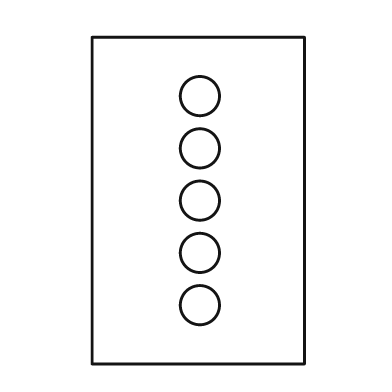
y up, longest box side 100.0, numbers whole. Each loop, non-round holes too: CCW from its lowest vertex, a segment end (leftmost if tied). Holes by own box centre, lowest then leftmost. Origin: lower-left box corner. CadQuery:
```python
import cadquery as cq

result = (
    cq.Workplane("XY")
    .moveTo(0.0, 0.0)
    .lineTo(65.0, 0.0)
    .lineTo(65.0, 100.0)
    .lineTo(0.0, 100.0)
    .close()
    .moveTo(33.0, 18.0)
    .circle(6.0)
    .moveTo(33.0, 34.0)
    .circle(6.0)
    .moveTo(33.0, 50.0)
    .circle(6.0)
    .moveTo(33.0, 66.0)
    .circle(6.0)
    .moveTo(33.0, 82.0)
    .circle(6.0)
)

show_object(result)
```